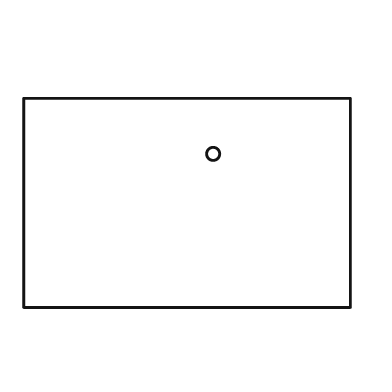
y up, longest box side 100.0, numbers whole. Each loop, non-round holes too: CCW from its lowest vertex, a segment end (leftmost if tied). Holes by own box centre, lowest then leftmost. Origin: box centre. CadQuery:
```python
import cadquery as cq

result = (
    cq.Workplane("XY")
    .moveTo(-50.0, -32.0)
    .lineTo(50.0, -32.0)
    .lineTo(50.0, 32.0)
    .lineTo(-50.0, 32.0)
    .close()
    .moveTo(8.0, 15.0)
    .circle(2.0)
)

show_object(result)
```